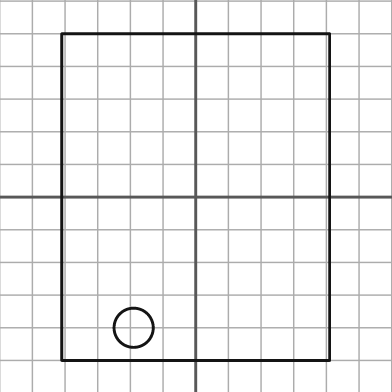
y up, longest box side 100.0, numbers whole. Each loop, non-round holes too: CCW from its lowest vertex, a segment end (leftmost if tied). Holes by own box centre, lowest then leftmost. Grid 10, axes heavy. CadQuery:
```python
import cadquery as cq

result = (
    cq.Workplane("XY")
    .moveTo(-41.0, -50.0)
    .lineTo(41.0, -50.0)
    .lineTo(41.0, 50.0)
    .lineTo(-41.0, 50.0)
    .close()
    .moveTo(-19.0, -40.0)
    .circle(6.0)
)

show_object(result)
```